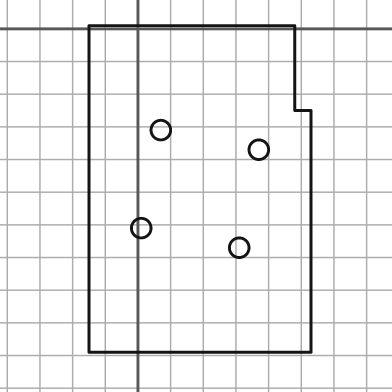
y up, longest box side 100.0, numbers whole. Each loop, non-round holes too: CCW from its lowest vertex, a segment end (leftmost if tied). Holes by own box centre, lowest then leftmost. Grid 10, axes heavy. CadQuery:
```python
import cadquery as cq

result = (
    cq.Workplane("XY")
    .moveTo(-15.0, -99.0)
    .lineTo(53.0, -99.0)
    .lineTo(53.0, -25.0)
    .lineTo(48.0, -25.0)
    .lineTo(48.0, 1.0)
    .lineTo(-15.0, 1.0)
    .close()
    .moveTo(31.0, -67.0)
    .circle(3.0)
    .moveTo(1.0, -61.0)
    .circle(3.0)
    .moveTo(37.0, -37.0)
    .circle(3.0)
    .moveTo(7.0, -31.0)
    .circle(3.0)
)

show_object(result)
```